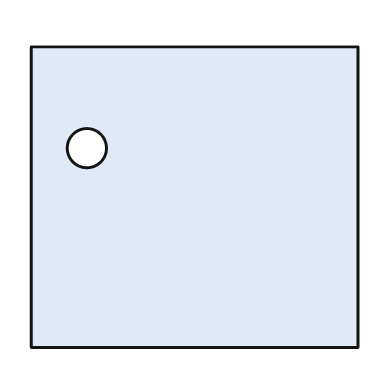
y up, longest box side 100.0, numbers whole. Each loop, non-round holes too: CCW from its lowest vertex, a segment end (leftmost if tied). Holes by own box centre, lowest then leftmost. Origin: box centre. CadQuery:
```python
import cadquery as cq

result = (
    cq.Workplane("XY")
    .moveTo(-50.0, -46.0)
    .lineTo(50.0, -46.0)
    .lineTo(50.0, 46.0)
    .lineTo(-50.0, 46.0)
    .close()
    .moveTo(-33.0, 15.0)
    .circle(6.0)
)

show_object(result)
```